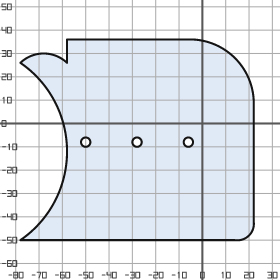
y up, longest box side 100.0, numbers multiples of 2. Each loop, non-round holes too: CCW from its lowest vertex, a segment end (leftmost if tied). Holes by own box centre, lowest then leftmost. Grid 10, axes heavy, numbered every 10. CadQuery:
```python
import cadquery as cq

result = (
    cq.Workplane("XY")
    .moveTo(-78.0, -50.0)
    .lineTo(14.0, -50.0)
    .threePointArc((20.0, -48.0), (22.0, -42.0))
    .lineTo(22.0, 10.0)
    .threePointArc((14.0, 28.0), (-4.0, 36.0))
    .lineTo(-58.0, 36.0)
    .lineTo(-58.0, 26.0)
    .threePointArc((-68.0, 30.0), (-78.0, 26.0))
    .threePointArc((-58.0, -12.0), (-78.0, -50.0))
    .close()
    .moveTo(-50.0, -8.0)
    .circle(2.0)
    .moveTo(-28.0, -8.0)
    .circle(2.0)
    .moveTo(-6.0, -8.0)
    .circle(2.0)
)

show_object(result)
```